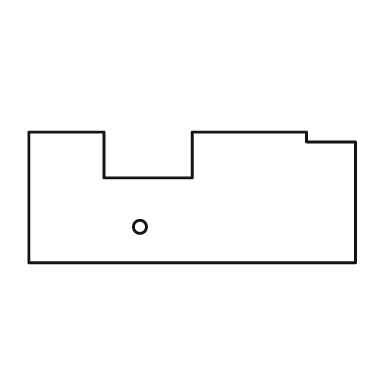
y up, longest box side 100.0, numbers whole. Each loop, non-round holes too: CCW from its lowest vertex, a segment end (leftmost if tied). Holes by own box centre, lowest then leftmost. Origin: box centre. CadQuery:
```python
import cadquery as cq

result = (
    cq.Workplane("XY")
    .moveTo(-50.0, -20.0)
    .lineTo(50.0, -20.0)
    .lineTo(50.0, 17.0)
    .lineTo(35.0, 17.0)
    .lineTo(35.0, 20.0)
    .lineTo(0.0, 20.0)
    .lineTo(0.0, 6.0)
    .lineTo(-27.0, 6.0)
    .lineTo(-27.0, 20.0)
    .lineTo(-50.0, 20.0)
    .close()
    .moveTo(-16.0, -9.0)
    .circle(2.0)
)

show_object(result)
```